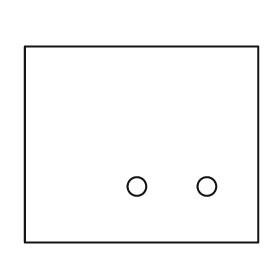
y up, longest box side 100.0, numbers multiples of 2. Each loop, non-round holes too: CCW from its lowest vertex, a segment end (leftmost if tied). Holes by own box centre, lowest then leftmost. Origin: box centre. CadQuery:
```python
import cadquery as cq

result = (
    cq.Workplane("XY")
    .moveTo(-50.0, -42.0)
    .lineTo(50.0, -42.0)
    .lineTo(50.0, 42.0)
    .lineTo(-50.0, 42.0)
    .close()
    .moveTo(-2.0, -18.0)
    .circle(4.0)
    .moveTo(28.0, -18.0)
    .circle(4.0)
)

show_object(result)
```